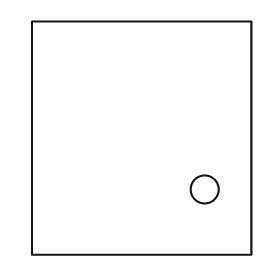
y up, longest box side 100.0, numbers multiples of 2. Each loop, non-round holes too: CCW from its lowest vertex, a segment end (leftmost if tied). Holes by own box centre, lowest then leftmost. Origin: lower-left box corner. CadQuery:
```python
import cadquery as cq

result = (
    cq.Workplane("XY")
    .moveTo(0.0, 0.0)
    .lineTo(94.0, 0.0)
    .lineTo(94.0, 100.0)
    .lineTo(0.0, 100.0)
    .close()
    .moveTo(74.0, 28.0)
    .circle(6.0)
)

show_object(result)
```